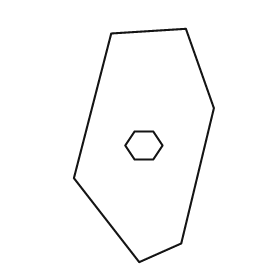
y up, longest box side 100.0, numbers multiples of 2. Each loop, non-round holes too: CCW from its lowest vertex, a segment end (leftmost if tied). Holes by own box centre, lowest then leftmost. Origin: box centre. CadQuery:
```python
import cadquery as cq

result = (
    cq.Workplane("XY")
    .moveTo(-2.0, -50.0)
    .lineTo(16.0, -42.0)
    .lineTo(30.0, 16.0)
    .lineTo(18.0, 50.0)
    .lineTo(-14.0, 48.0)
    .lineTo(-30.0, -14.0)
    .close()
    .moveTo(-4.0, -6.0)
    .lineTo(4.0, -6.0)
    .lineTo(8.0, 0.0)
    .lineTo(4.0, 6.0)
    .lineTo(-4.0, 6.0)
    .lineTo(-8.0, 0.0)
    .close()
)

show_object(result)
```